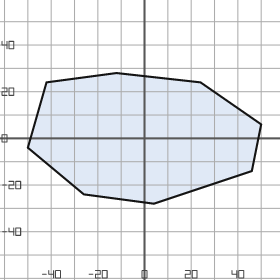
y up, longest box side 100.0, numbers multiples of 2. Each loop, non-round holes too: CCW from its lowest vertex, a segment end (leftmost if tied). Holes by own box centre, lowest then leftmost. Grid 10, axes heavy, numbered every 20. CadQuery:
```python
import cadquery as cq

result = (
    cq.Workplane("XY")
    .moveTo(4.0, -28.0)
    .lineTo(46.0, -14.0)
    .lineTo(50.0, 6.0)
    .lineTo(24.0, 24.0)
    .lineTo(-12.0, 28.0)
    .lineTo(-42.0, 24.0)
    .lineTo(-50.0, -4.0)
    .lineTo(-26.0, -24.0)
    .close()
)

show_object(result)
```